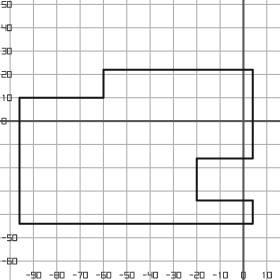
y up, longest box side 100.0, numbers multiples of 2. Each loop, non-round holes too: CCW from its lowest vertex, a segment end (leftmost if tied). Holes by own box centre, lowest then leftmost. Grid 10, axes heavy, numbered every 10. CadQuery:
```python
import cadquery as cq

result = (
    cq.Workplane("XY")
    .moveTo(-96.0, -44.0)
    .lineTo(4.0, -44.0)
    .lineTo(4.0, -34.0)
    .lineTo(-20.0, -34.0)
    .lineTo(-20.0, -16.0)
    .lineTo(4.0, -16.0)
    .lineTo(4.0, 22.0)
    .lineTo(-60.0, 22.0)
    .lineTo(-60.0, 10.0)
    .lineTo(-96.0, 10.0)
    .close()
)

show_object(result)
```